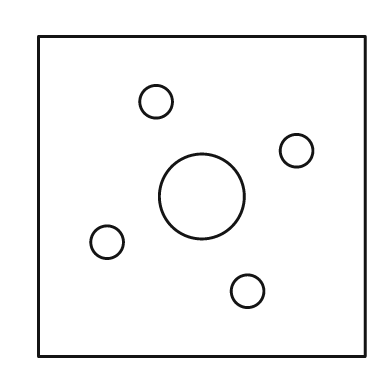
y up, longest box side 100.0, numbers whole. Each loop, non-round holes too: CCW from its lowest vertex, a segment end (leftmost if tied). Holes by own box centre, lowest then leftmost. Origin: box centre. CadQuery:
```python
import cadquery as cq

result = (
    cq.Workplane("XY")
    .moveTo(-50.0, -49.0)
    .lineTo(50.0, -49.0)
    .lineTo(50.0, 49.0)
    .lineTo(-50.0, 49.0)
    .close()
    .moveTo(14.0, -29.0)
    .circle(5.0)
    .moveTo(-29.0, -14.0)
    .circle(5.0)
    .moveTo(0.0, 0.0)
    .circle(13.0)
    .moveTo(29.0, 14.0)
    .circle(5.0)
    .moveTo(-14.0, 29.0)
    .circle(5.0)
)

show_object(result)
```